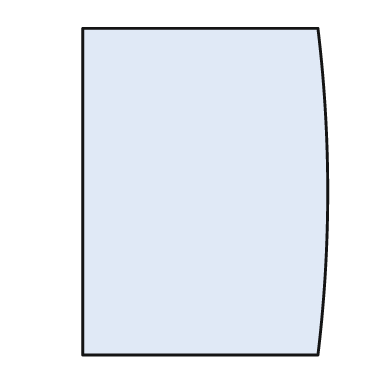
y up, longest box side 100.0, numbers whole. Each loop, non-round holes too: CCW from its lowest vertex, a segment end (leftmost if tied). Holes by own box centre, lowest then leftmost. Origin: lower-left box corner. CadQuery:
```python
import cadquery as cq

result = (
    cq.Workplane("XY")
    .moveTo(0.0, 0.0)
    .lineTo(72.0, 0.0)
    .threePointArc((75.0, 50.0), (72.0, 100.0))
    .lineTo(0.0, 100.0)
    .close()
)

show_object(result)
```